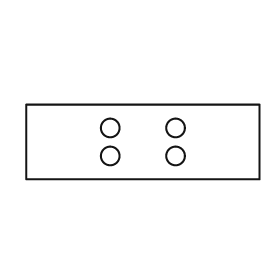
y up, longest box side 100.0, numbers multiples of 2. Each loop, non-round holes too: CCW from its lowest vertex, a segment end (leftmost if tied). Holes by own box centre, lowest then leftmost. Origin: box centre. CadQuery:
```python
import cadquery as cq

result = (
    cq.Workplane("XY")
    .moveTo(-50.0, -16.0)
    .lineTo(50.0, -16.0)
    .lineTo(50.0, 16.0)
    .lineTo(-50.0, 16.0)
    .close()
    .moveTo(-14.0, -6.0)
    .circle(4.0)
    .moveTo(14.0, -6.0)
    .circle(4.0)
    .moveTo(-14.0, 6.0)
    .circle(4.0)
    .moveTo(14.0, 6.0)
    .circle(4.0)
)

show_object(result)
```